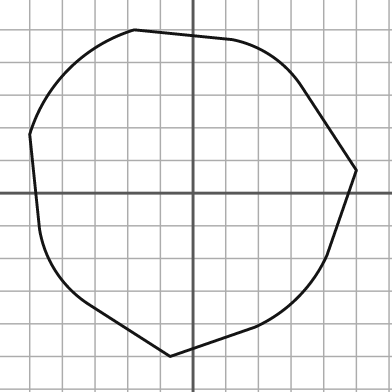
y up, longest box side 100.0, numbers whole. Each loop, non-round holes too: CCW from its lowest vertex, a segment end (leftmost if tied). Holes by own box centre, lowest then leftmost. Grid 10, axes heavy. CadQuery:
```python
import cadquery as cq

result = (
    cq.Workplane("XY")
    .moveTo(-7.0, -50.0)
    .lineTo(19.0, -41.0)
    .threePointArc((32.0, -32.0), (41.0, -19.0))
    .lineTo(50.0, 7.0)
    .lineTo(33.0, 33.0)
    .threePointArc((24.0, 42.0), (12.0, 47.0))
    .lineTo(-18.0, 50.0)
    .threePointArc((-38.0, 38.0), (-50.0, 18.0))
    .lineTo(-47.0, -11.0)
    .threePointArc((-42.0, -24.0), (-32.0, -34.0))
    .close()
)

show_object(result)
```